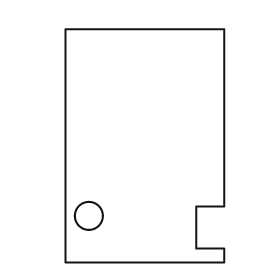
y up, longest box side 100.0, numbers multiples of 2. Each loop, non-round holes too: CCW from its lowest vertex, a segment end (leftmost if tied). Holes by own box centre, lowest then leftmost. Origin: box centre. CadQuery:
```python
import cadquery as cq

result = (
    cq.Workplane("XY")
    .moveTo(-34.0, -50.0)
    .lineTo(34.0, -50.0)
    .lineTo(34.0, -44.0)
    .lineTo(22.0, -44.0)
    .lineTo(22.0, -26.0)
    .lineTo(34.0, -26.0)
    .lineTo(34.0, 50.0)
    .lineTo(-34.0, 50.0)
    .close()
    .moveTo(-24.0, -30.0)
    .circle(6.0)
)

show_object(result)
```